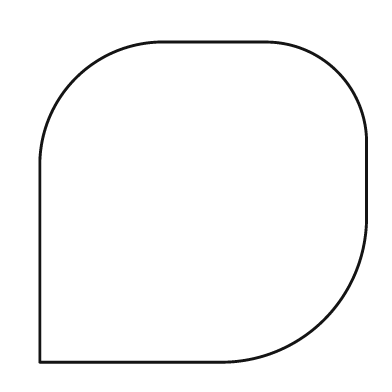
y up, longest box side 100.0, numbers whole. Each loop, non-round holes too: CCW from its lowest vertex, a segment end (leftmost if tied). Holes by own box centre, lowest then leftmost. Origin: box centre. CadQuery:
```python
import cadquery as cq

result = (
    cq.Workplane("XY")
    .moveTo(-50.0, -49.0)
    .lineTo(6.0, -49.0)
    .threePointArc((37.0, -36.0), (50.0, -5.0))
    .lineTo(50.0, 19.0)
    .threePointArc((41.0, 40.0), (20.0, 49.0))
    .lineTo(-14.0, 49.0)
    .threePointArc((-39.0, 38.0), (-50.0, 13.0))
    .close()
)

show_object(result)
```